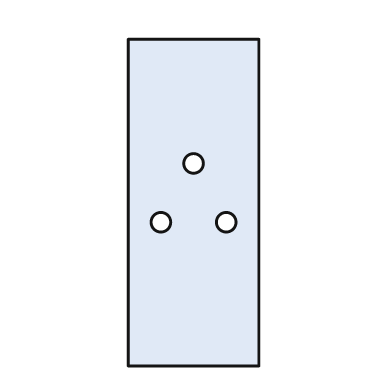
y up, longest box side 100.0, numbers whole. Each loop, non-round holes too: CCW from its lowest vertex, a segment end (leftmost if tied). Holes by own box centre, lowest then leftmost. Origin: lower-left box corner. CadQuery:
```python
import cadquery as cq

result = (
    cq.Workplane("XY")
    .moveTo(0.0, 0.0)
    .lineTo(40.0, 0.0)
    .lineTo(40.0, 100.0)
    .lineTo(0.0, 100.0)
    .close()
    .moveTo(10.0, 44.0)
    .circle(3.0)
    .moveTo(30.0, 44.0)
    .circle(3.0)
    .moveTo(20.0, 62.0)
    .circle(3.0)
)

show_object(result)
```